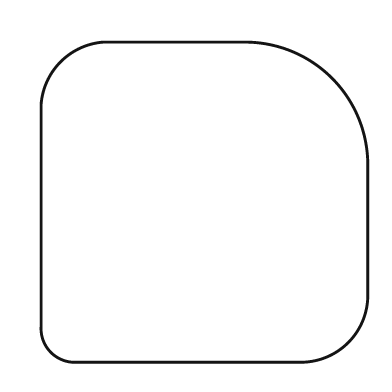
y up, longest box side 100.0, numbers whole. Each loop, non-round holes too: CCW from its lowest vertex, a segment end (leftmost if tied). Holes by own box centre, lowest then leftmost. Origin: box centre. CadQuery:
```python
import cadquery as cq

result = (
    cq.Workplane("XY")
    .moveTo(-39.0, -49.0)
    .lineTo(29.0, -49.0)
    .threePointArc((44.0, -43.0), (50.0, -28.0))
    .lineTo(50.0, 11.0)
    .threePointArc((39.0, 38.0), (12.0, 49.0))
    .lineTo(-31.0, 49.0)
    .threePointArc((-44.0, 43.0), (-50.0, 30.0))
    .lineTo(-50.0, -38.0)
    .threePointArc((-47.0, -46.0), (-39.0, -49.0))
    .close()
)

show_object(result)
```